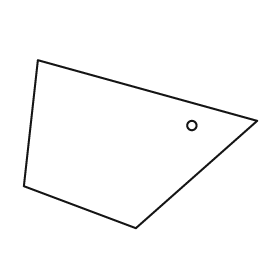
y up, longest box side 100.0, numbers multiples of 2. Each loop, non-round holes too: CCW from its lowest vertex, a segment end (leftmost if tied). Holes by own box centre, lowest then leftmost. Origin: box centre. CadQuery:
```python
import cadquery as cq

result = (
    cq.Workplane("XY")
    .moveTo(-2.0, -36.0)
    .lineTo(50.0, 10.0)
    .lineTo(-44.0, 36.0)
    .lineTo(-50.0, -18.0)
    .close()
    .moveTo(22.0, 8.0)
    .circle(2.0)
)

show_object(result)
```